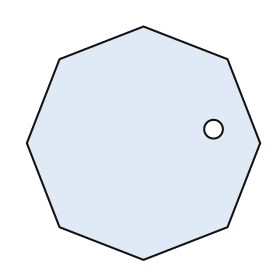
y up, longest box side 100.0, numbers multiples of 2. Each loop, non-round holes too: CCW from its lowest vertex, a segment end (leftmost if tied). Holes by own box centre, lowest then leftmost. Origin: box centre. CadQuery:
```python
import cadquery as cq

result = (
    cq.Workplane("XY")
    .moveTo(0.0, -50.0)
    .lineTo(36.0, -36.0)
    .lineTo(50.0, 0.0)
    .lineTo(36.0, 36.0)
    .lineTo(0.0, 50.0)
    .lineTo(-36.0, 36.0)
    .lineTo(-50.0, 0.0)
    .lineTo(-36.0, -36.0)
    .close()
    .moveTo(30.0, 6.0)
    .circle(4.0)
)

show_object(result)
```